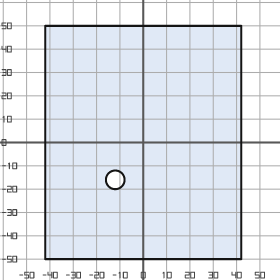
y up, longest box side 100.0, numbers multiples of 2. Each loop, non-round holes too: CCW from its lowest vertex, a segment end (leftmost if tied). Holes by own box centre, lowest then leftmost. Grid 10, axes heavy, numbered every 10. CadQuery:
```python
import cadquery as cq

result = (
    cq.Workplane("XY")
    .moveTo(-42.0, -50.0)
    .lineTo(42.0, -50.0)
    .lineTo(42.0, 50.0)
    .lineTo(-42.0, 50.0)
    .close()
    .moveTo(-12.0, -16.0)
    .circle(4.0)
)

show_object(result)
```